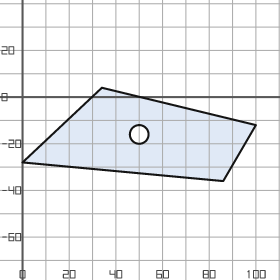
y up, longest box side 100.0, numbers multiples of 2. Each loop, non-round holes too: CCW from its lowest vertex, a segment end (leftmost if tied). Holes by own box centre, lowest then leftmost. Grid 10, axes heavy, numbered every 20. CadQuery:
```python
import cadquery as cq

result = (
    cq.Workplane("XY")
    .moveTo(86.0, -36.0)
    .lineTo(100.0, -12.0)
    .lineTo(34.0, 4.0)
    .lineTo(0.0, -28.0)
    .close()
    .moveTo(50.0, -16.0)
    .circle(4.0)
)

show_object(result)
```